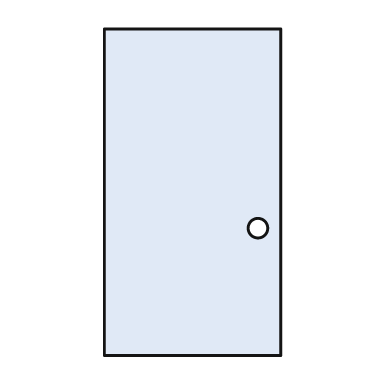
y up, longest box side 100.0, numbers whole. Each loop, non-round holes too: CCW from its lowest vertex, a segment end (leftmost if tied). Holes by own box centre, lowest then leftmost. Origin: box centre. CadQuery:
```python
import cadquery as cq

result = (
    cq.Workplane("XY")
    .moveTo(-27.0, -50.0)
    .lineTo(27.0, -50.0)
    .lineTo(27.0, 50.0)
    .lineTo(-27.0, 50.0)
    .close()
    .moveTo(20.0, -11.0)
    .circle(3.0)
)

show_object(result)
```